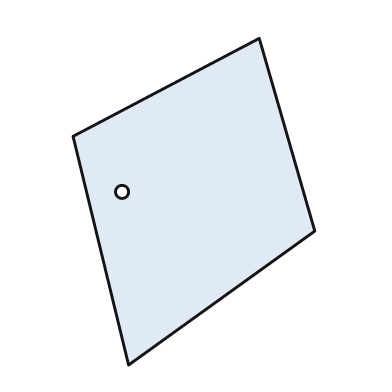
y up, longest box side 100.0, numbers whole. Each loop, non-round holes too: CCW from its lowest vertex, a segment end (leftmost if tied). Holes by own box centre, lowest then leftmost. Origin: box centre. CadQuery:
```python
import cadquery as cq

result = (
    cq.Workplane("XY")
    .moveTo(-20.0, -50.0)
    .lineTo(37.0, -9.0)
    .lineTo(20.0, 50.0)
    .lineTo(-37.0, 20.0)
    .close()
    .moveTo(-22.0, 3.0)
    .circle(2.0)
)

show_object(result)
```